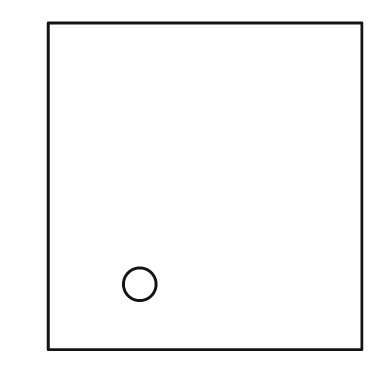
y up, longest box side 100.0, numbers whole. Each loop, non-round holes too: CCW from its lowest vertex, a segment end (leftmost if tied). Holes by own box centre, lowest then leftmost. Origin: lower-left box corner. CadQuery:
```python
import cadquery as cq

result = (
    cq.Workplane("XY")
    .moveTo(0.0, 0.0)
    .lineTo(96.0, 0.0)
    .lineTo(96.0, 100.0)
    .lineTo(0.0, 100.0)
    .close()
    .moveTo(28.0, 20.0)
    .circle(5.0)
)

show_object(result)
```